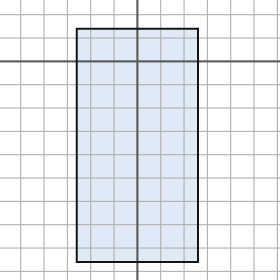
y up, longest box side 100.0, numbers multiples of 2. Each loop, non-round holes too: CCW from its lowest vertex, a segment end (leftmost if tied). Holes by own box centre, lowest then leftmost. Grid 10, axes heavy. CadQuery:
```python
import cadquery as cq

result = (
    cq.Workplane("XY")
    .moveTo(-26.0, -86.0)
    .lineTo(26.0, -86.0)
    .lineTo(26.0, 14.0)
    .lineTo(-26.0, 14.0)
    .close()
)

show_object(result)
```